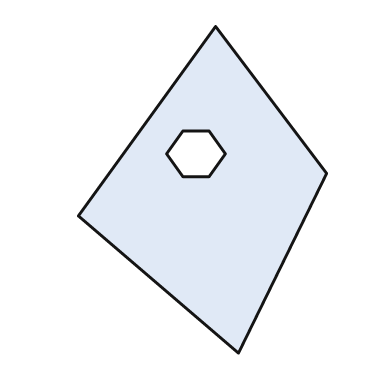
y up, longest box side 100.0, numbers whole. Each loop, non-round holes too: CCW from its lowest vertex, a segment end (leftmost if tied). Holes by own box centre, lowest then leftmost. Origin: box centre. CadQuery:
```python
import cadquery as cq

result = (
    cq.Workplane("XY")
    .moveTo(11.0, -50.0)
    .lineTo(38.0, 5.0)
    .lineTo(4.0, 50.0)
    .lineTo(-38.0, -8.0)
    .close()
    .moveTo(-6.0, 4.0)
    .lineTo(2.0, 4.0)
    .lineTo(7.0, 11.0)
    .lineTo(2.0, 18.0)
    .lineTo(-6.0, 18.0)
    .lineTo(-11.0, 11.0)
    .close()
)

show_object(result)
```